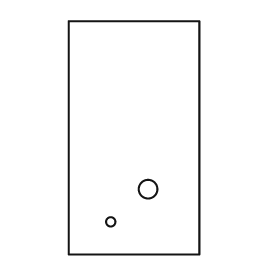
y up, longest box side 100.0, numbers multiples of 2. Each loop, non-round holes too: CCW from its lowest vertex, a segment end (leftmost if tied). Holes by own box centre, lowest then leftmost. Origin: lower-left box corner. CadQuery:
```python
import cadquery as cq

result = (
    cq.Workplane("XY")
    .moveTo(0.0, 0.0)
    .lineTo(56.0, 0.0)
    .lineTo(56.0, 100.0)
    .lineTo(0.0, 100.0)
    .close()
    .moveTo(18.0, 14.0)
    .circle(2.0)
    .moveTo(34.0, 28.0)
    .circle(4.0)
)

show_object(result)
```